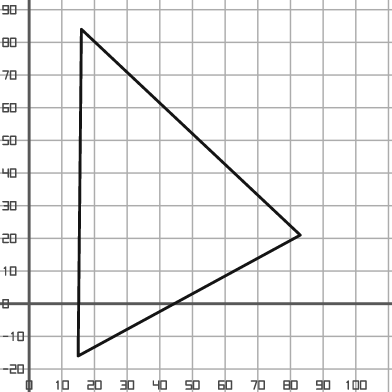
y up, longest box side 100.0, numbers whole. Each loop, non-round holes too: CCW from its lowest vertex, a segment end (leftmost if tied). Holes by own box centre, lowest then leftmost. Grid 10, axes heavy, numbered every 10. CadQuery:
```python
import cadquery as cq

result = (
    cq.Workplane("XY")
    .moveTo(15.0, -16.0)
    .lineTo(83.0, 21.0)
    .lineTo(16.0, 84.0)
    .close()
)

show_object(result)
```